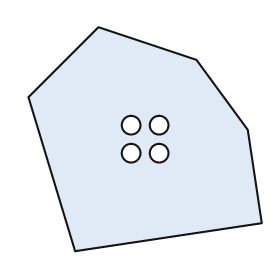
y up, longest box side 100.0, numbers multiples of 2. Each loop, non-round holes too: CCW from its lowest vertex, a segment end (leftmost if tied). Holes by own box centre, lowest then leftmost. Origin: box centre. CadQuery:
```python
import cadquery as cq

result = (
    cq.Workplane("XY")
    .moveTo(-30.0, -48.0)
    .lineTo(50.0, -36.0)
    .lineTo(44.0, 4.0)
    .lineTo(22.0, 34.0)
    .lineTo(-20.0, 48.0)
    .lineTo(-50.0, 18.0)
    .close()
    .moveTo(-6.0, -6.0)
    .circle(4.0)
    .moveTo(6.0, -6.0)
    .circle(4.0)
    .moveTo(-6.0, 6.0)
    .circle(4.0)
    .moveTo(6.0, 6.0)
    .circle(4.0)
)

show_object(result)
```